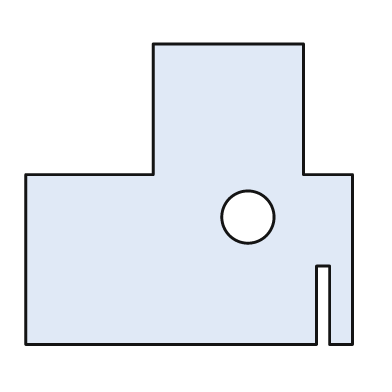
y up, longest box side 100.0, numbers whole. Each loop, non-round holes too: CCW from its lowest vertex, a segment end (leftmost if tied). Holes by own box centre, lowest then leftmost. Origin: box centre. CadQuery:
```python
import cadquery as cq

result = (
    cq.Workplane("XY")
    .moveTo(-50.0, -46.0)
    .lineTo(39.0, -46.0)
    .lineTo(39.0, -22.0)
    .lineTo(43.0, -22.0)
    .lineTo(43.0, -46.0)
    .lineTo(50.0, -46.0)
    .lineTo(50.0, 6.0)
    .lineTo(35.0, 6.0)
    .lineTo(35.0, 46.0)
    .lineTo(-11.0, 46.0)
    .lineTo(-11.0, 6.0)
    .lineTo(-50.0, 6.0)
    .close()
    .moveTo(18.0, -7.0)
    .circle(8.0)
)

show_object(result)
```